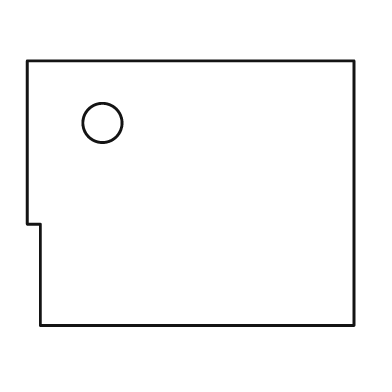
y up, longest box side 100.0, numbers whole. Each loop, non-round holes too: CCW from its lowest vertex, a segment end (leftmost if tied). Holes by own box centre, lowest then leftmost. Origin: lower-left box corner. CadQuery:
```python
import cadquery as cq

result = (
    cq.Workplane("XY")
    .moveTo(4.0, 0.0)
    .lineTo(100.0, 0.0)
    .lineTo(100.0, 81.0)
    .lineTo(0.0, 81.0)
    .lineTo(0.0, 31.0)
    .lineTo(4.0, 31.0)
    .close()
    .moveTo(23.0, 62.0)
    .circle(6.0)
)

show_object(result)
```